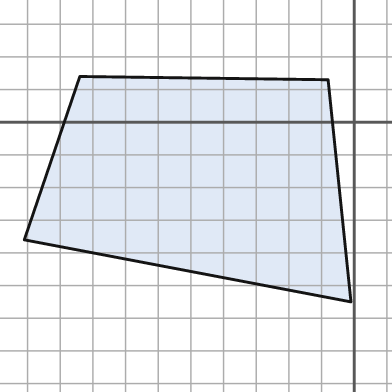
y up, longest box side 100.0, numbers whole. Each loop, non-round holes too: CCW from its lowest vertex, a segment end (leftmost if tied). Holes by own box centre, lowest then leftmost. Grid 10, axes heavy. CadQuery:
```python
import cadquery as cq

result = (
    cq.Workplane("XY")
    .moveTo(-1.0, -55.0)
    .lineTo(-8.0, 13.0)
    .lineTo(-84.0, 14.0)
    .lineTo(-101.0, -36.0)
    .close()
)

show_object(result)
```